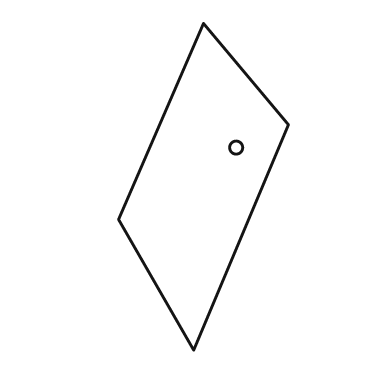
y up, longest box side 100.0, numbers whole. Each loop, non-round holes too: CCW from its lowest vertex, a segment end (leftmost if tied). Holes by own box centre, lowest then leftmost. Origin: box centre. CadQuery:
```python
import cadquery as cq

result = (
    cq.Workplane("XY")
    .moveTo(-3.0, -50.0)
    .lineTo(26.0, 19.0)
    .lineTo(0.0, 50.0)
    .lineTo(-26.0, -10.0)
    .close()
    .moveTo(10.0, 12.0)
    .circle(2.0)
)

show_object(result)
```